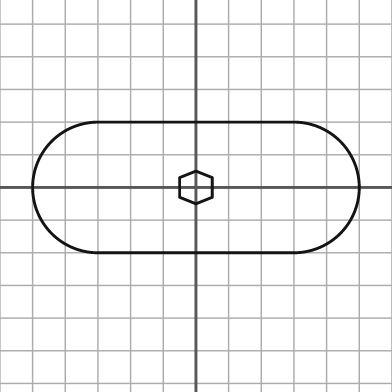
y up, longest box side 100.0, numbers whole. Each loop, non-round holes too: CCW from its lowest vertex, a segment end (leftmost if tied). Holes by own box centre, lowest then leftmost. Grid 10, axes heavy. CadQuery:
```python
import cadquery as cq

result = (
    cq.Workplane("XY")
    .moveTo(-30.0, -20.0)
    .lineTo(30.0, -20.0)
    .threePointArc((50.0, 0.0), (30.0, 20.0))
    .lineTo(-30.0, 20.0)
    .threePointArc((-50.0, 0.0), (-30.0, -20.0))
    .close()
    .moveTo(0.0, -5.0)
    .lineTo(5.0, -3.0)
    .lineTo(5.0, 3.0)
    .lineTo(0.0, 5.0)
    .lineTo(-5.0, 3.0)
    .lineTo(-5.0, -3.0)
    .close()
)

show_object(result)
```